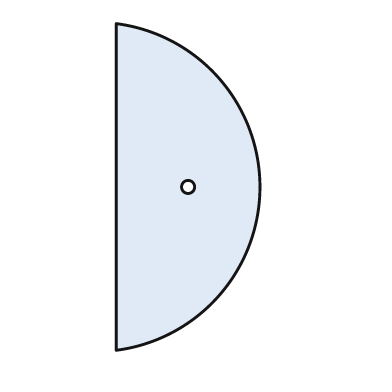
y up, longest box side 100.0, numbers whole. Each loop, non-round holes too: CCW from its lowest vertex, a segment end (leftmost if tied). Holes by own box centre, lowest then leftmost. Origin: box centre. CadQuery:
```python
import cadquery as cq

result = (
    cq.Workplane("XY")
    .moveTo(-22.0, -50.0)
    .threePointArc((22.0, 0.0), (-22.0, 50.0))
    .close()
    .moveTo(0.0, 0.0)
    .circle(2.0)
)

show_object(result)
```